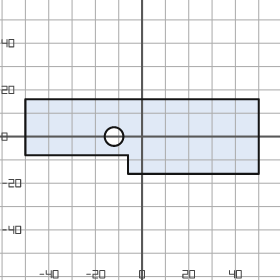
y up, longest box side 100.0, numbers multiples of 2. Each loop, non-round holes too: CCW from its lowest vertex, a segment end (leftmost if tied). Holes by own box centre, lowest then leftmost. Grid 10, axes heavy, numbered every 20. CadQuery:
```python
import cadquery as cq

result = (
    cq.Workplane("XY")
    .moveTo(-6.0, -16.0)
    .lineTo(50.0, -16.0)
    .lineTo(50.0, 16.0)
    .lineTo(-50.0, 16.0)
    .lineTo(-50.0, -8.0)
    .lineTo(-6.0, -8.0)
    .close()
    .moveTo(-12.0, 0.0)
    .circle(4.0)
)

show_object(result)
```